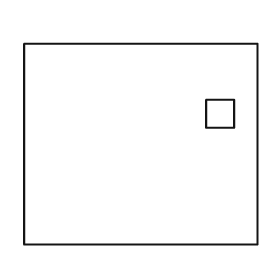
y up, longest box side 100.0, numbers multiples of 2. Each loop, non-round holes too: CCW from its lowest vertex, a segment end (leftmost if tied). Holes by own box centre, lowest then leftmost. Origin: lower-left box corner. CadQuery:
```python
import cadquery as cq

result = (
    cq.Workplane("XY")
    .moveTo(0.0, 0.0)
    .lineTo(100.0, 0.0)
    .lineTo(100.0, 86.0)
    .lineTo(0.0, 86.0)
    .close()
    .moveTo(78.0, 50.0)
    .lineTo(90.0, 50.0)
    .lineTo(90.0, 62.0)
    .lineTo(78.0, 62.0)
    .close()
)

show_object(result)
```